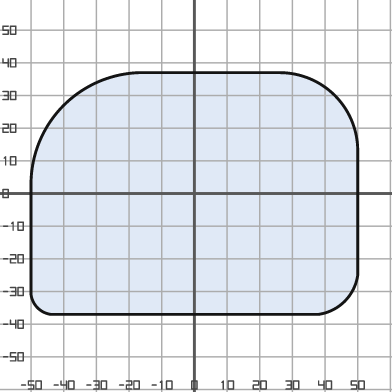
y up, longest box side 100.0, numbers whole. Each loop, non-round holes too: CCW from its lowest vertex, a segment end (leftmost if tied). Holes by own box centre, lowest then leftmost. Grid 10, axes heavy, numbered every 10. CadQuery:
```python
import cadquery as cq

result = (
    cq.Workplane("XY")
    .moveTo(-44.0, -37.0)
    .lineTo(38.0, -37.0)
    .threePointArc((46.0, -33.0), (50.0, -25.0))
    .lineTo(50.0, 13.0)
    .threePointArc((43.0, 30.0), (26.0, 37.0))
    .lineTo(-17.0, 37.0)
    .threePointArc((-40.0, 27.0), (-50.0, 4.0))
    .lineTo(-50.0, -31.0)
    .threePointArc((-48.0, -35.0), (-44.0, -37.0))
    .close()
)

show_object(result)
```